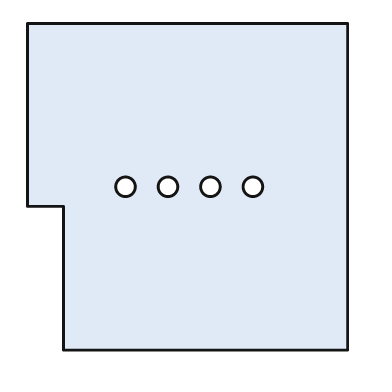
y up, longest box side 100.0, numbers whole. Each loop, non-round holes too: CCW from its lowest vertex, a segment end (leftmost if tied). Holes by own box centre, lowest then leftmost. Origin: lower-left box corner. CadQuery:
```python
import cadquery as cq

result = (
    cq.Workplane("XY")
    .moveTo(11.0, 0.0)
    .lineTo(98.0, 0.0)
    .lineTo(98.0, 100.0)
    .lineTo(0.0, 100.0)
    .lineTo(0.0, 44.0)
    .lineTo(11.0, 44.0)
    .close()
    .moveTo(30.0, 50.0)
    .circle(3.0)
    .moveTo(43.0, 50.0)
    .circle(3.0)
    .moveTo(56.0, 50.0)
    .circle(3.0)
    .moveTo(69.0, 50.0)
    .circle(3.0)
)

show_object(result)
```